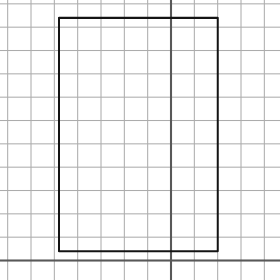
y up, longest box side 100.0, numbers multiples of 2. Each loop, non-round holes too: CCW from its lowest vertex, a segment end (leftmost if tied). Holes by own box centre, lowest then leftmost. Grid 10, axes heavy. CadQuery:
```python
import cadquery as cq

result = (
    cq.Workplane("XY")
    .moveTo(-48.0, 4.0)
    .lineTo(20.0, 4.0)
    .lineTo(20.0, 104.0)
    .lineTo(-48.0, 104.0)
    .close()
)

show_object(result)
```